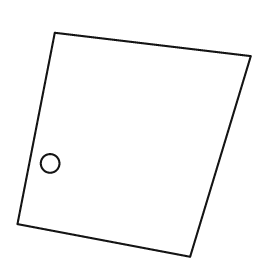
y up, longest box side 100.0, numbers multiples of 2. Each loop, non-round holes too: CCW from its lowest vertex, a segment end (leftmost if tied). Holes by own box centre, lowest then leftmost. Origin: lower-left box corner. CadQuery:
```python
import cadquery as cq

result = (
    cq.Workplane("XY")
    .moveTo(74.0, 0.0)
    .lineTo(100.0, 86.0)
    .lineTo(16.0, 96.0)
    .lineTo(0.0, 14.0)
    .close()
    .moveTo(14.0, 40.0)
    .circle(4.0)
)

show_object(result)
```